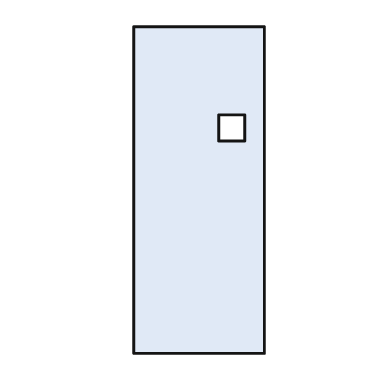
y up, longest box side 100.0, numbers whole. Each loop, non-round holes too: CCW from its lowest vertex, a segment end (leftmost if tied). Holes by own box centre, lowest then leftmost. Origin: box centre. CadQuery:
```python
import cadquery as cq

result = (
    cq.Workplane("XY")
    .moveTo(-20.0, -50.0)
    .lineTo(20.0, -50.0)
    .lineTo(20.0, 50.0)
    .lineTo(-20.0, 50.0)
    .close()
    .moveTo(6.0, 15.0)
    .lineTo(14.0, 15.0)
    .lineTo(14.0, 23.0)
    .lineTo(6.0, 23.0)
    .close()
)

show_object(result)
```